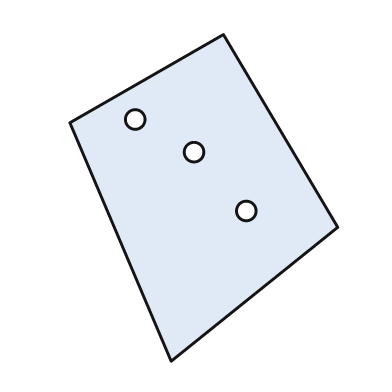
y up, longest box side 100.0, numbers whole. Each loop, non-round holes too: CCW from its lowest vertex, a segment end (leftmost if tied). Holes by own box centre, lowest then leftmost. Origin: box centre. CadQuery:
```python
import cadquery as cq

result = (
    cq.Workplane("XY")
    .moveTo(-10.0, -50.0)
    .lineTo(41.0, -9.0)
    .lineTo(6.0, 50.0)
    .lineTo(-41.0, 23.0)
    .close()
    .moveTo(13.0, -4.0)
    .circle(3.0)
    .moveTo(-3.0, 14.0)
    .circle(3.0)
    .moveTo(-21.0, 24.0)
    .circle(3.0)
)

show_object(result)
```